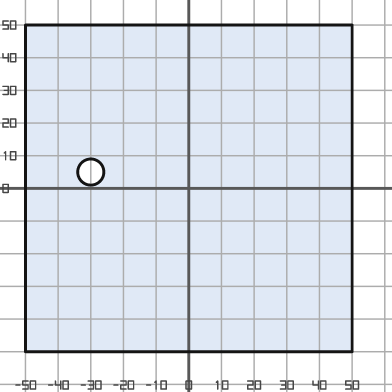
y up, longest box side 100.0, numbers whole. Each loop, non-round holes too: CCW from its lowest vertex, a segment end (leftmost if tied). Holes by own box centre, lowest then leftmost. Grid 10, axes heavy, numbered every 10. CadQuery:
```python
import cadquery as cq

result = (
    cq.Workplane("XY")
    .moveTo(-50.0, -50.0)
    .lineTo(50.0, -50.0)
    .lineTo(50.0, 50.0)
    .lineTo(-50.0, 50.0)
    .close()
    .moveTo(-30.0, 5.0)
    .circle(4.0)
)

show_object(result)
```